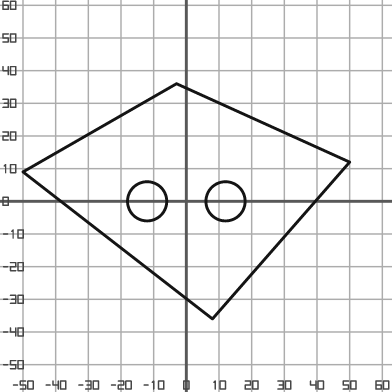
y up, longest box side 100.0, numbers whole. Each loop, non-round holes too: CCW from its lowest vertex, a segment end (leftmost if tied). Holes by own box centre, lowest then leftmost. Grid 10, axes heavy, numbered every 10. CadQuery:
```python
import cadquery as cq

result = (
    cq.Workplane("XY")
    .moveTo(8.0, -36.0)
    .lineTo(50.0, 12.0)
    .lineTo(-3.0, 36.0)
    .lineTo(-50.0, 9.0)
    .close()
    .moveTo(-12.0, 0.0)
    .circle(6.0)
    .moveTo(12.0, 0.0)
    .circle(6.0)
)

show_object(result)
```